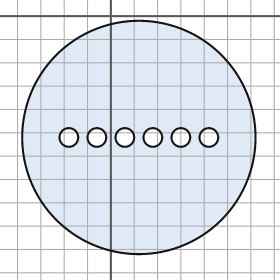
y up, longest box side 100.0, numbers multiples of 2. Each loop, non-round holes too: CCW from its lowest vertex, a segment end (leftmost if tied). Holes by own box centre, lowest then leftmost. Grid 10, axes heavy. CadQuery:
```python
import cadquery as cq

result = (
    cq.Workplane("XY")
    .moveTo(12.0, -52.0)
    .circle(50.0)
    .moveTo(-18.0, -52.0)
    .circle(4.0)
    .moveTo(-6.0, -52.0)
    .circle(4.0)
    .moveTo(6.0, -52.0)
    .circle(4.0)
    .moveTo(18.0, -52.0)
    .circle(4.0)
    .moveTo(30.0, -52.0)
    .circle(4.0)
    .moveTo(42.0, -52.0)
    .circle(4.0)
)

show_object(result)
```